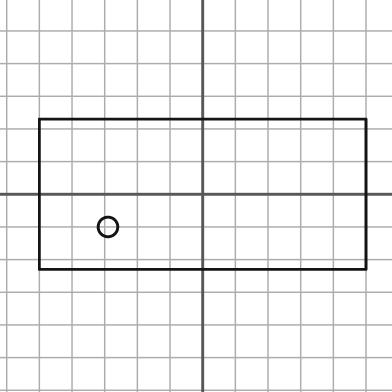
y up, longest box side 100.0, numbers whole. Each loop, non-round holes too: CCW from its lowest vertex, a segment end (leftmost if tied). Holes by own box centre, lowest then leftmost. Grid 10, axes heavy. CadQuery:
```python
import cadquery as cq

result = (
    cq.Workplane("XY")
    .moveTo(-50.0, -23.0)
    .lineTo(50.0, -23.0)
    .lineTo(50.0, 23.0)
    .lineTo(-50.0, 23.0)
    .close()
    .moveTo(-29.0, -10.0)
    .circle(3.0)
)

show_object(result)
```